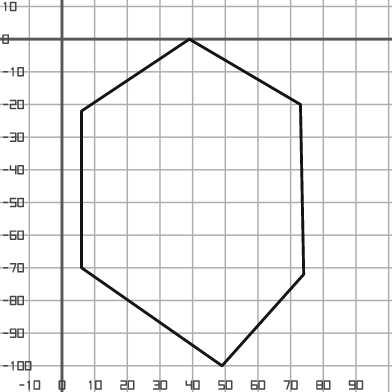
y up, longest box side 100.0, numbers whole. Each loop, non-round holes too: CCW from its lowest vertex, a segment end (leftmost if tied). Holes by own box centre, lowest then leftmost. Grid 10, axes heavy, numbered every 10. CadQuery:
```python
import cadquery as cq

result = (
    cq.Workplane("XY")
    .moveTo(49.0, -100.0)
    .lineTo(74.0, -72.0)
    .lineTo(73.0, -20.0)
    .lineTo(39.0, 0.0)
    .lineTo(6.0, -22.0)
    .lineTo(6.0, -70.0)
    .close()
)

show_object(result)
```